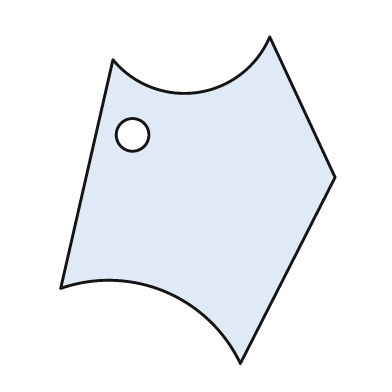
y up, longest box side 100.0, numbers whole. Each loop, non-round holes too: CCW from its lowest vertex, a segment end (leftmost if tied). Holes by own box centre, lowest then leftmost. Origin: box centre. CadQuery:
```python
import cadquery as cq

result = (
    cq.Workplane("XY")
    .moveTo(13.0, -50.0)
    .lineTo(42.0, 7.0)
    .lineTo(22.0, 50.0)
    .threePointArc((0.0, 33.0), (-26.0, 43.0))
    .lineTo(-42.0, -27.0)
    .threePointArc((-10.0, -28.0), (13.0, -50.0))
    .close()
    .moveTo(-20.0, 20.0)
    .circle(5.0)
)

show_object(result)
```